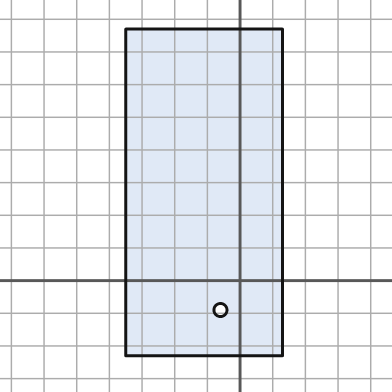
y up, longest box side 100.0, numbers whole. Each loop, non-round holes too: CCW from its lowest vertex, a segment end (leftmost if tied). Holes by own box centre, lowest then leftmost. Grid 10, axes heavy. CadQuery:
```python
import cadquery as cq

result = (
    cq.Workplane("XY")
    .moveTo(-35.0, -23.0)
    .lineTo(13.0, -23.0)
    .lineTo(13.0, 77.0)
    .lineTo(-35.0, 77.0)
    .close()
    .moveTo(-6.0, -9.0)
    .circle(2.0)
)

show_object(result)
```